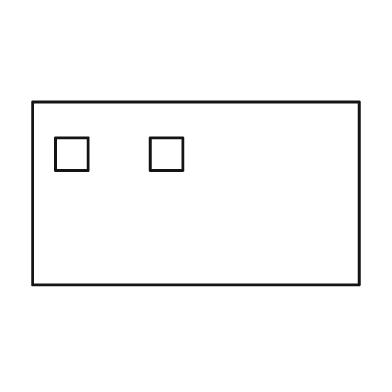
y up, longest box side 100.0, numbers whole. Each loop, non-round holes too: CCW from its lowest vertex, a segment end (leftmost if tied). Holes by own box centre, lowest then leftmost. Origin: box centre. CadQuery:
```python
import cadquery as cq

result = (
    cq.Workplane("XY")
    .moveTo(-50.0, -28.0)
    .lineTo(50.0, -28.0)
    .lineTo(50.0, 28.0)
    .lineTo(-50.0, 28.0)
    .close()
    .moveTo(-43.0, 7.0)
    .lineTo(-33.0, 7.0)
    .lineTo(-33.0, 17.0)
    .lineTo(-43.0, 17.0)
    .close()
    .moveTo(-14.0, 7.0)
    .lineTo(-4.0, 7.0)
    .lineTo(-4.0, 17.0)
    .lineTo(-14.0, 17.0)
    .close()
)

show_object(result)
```